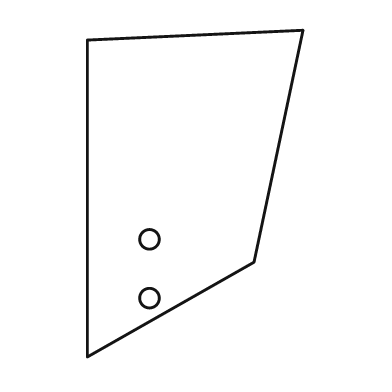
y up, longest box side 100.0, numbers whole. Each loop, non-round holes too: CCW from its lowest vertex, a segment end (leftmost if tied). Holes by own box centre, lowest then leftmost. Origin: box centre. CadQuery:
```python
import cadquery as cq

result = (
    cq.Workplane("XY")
    .moveTo(-33.0, -50.0)
    .lineTo(18.0, -21.0)
    .lineTo(33.0, 50.0)
    .lineTo(-33.0, 47.0)
    .close()
    .moveTo(-14.0, -32.0)
    .circle(3.0)
    .moveTo(-14.0, -14.0)
    .circle(3.0)
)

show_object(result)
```